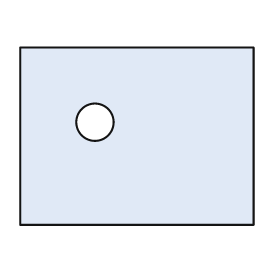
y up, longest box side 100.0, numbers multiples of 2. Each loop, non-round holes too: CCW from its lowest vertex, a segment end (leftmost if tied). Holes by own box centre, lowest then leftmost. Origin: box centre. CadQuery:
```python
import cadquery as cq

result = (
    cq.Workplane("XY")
    .moveTo(-50.0, -38.0)
    .lineTo(50.0, -38.0)
    .lineTo(50.0, 38.0)
    .lineTo(-50.0, 38.0)
    .close()
    .moveTo(-18.0, 6.0)
    .circle(8.0)
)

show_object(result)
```